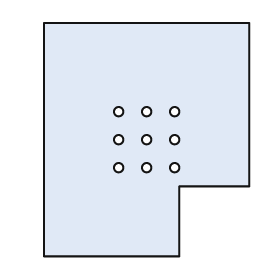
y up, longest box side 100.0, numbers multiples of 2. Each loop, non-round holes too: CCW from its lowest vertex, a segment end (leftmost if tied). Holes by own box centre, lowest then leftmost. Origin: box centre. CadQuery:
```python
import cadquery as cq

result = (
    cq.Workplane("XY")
    .moveTo(-44.0, -50.0)
    .lineTo(14.0, -50.0)
    .lineTo(14.0, -20.0)
    .lineTo(44.0, -20.0)
    .lineTo(44.0, 50.0)
    .lineTo(-44.0, 50.0)
    .close()
    .moveTo(-12.0, -12.0)
    .circle(2.0)
    .moveTo(0.0, -12.0)
    .circle(2.0)
    .moveTo(12.0, -12.0)
    .circle(2.0)
    .moveTo(-12.0, 0.0)
    .circle(2.0)
    .moveTo(0.0, 0.0)
    .circle(2.0)
    .moveTo(12.0, 0.0)
    .circle(2.0)
    .moveTo(-12.0, 12.0)
    .circle(2.0)
    .moveTo(0.0, 12.0)
    .circle(2.0)
    .moveTo(12.0, 12.0)
    .circle(2.0)
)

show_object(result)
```